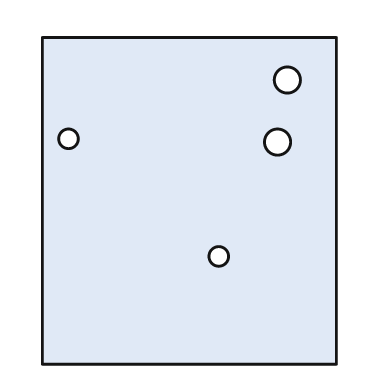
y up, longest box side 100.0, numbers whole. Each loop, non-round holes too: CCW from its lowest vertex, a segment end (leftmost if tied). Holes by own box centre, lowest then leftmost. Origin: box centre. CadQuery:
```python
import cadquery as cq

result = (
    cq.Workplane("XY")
    .moveTo(-45.0, -50.0)
    .lineTo(45.0, -50.0)
    .lineTo(45.0, 50.0)
    .lineTo(-45.0, 50.0)
    .close()
    .moveTo(9.0, -17.0)
    .circle(3.0)
    .moveTo(27.0, 18.0)
    .circle(4.0)
    .moveTo(-37.0, 19.0)
    .circle(3.0)
    .moveTo(30.0, 37.0)
    .circle(4.0)
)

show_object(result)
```